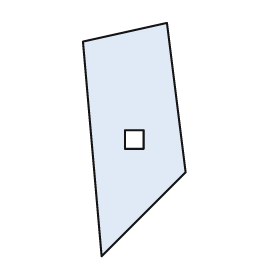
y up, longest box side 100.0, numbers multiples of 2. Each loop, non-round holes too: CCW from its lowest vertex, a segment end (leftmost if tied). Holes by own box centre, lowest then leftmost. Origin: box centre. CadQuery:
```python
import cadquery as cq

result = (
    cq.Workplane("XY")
    .moveTo(-14.0, -50.0)
    .lineTo(22.0, -14.0)
    .lineTo(14.0, 50.0)
    .lineTo(-22.0, 42.0)
    .close()
    .moveTo(-4.0, -4.0)
    .lineTo(4.0, -4.0)
    .lineTo(4.0, 4.0)
    .lineTo(-4.0, 4.0)
    .close()
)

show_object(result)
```